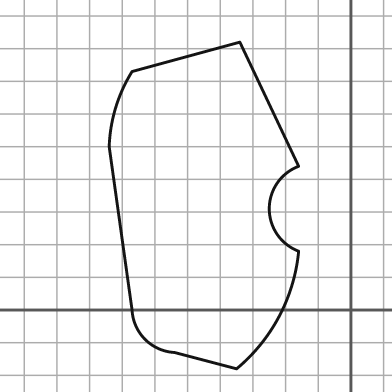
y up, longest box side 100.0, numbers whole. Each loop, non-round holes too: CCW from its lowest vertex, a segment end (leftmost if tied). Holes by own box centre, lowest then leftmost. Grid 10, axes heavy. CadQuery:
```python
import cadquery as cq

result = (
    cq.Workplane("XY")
    .moveTo(-35.0, -18.0)
    .threePointArc((-22.0, -2.0), (-16.0, 18.0))
    .threePointArc((-25.0, 31.0), (-16.0, 44.0))
    .lineTo(-34.0, 82.0)
    .lineTo(-67.0, 73.0)
    .threePointArc((-72.0, 62.0), (-74.0, 50.0))
    .lineTo(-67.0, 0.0)
    .threePointArc((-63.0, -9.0), (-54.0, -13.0))
    .close()
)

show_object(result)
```